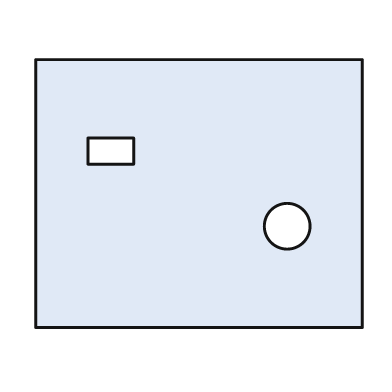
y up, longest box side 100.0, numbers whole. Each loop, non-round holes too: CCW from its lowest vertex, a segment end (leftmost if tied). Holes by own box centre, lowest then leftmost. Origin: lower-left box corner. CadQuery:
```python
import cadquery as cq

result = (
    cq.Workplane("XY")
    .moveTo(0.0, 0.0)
    .lineTo(100.0, 0.0)
    .lineTo(100.0, 82.0)
    .lineTo(0.0, 82.0)
    .close()
    .moveTo(77.0, 31.0)
    .circle(7.0)
    .moveTo(16.0, 50.0)
    .lineTo(30.0, 50.0)
    .lineTo(30.0, 58.0)
    .lineTo(16.0, 58.0)
    .close()
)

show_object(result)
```